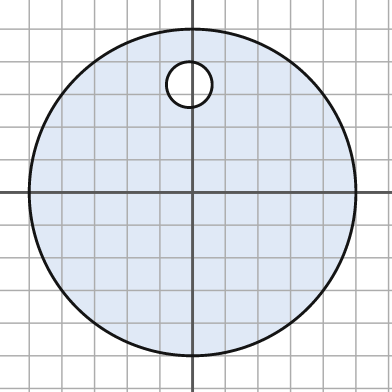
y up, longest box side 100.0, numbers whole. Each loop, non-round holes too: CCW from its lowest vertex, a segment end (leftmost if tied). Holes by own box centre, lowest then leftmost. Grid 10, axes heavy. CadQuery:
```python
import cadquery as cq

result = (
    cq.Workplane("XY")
    .moveTo(0.0, 0.0)
    .circle(50.0)
    .moveTo(-1.0, 33.0)
    .circle(7.0)
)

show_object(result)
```